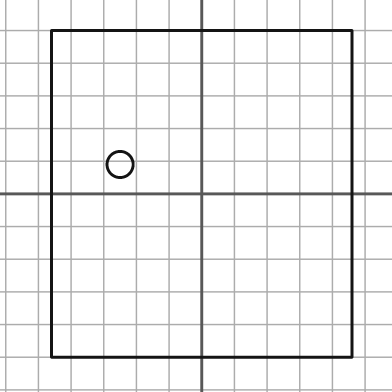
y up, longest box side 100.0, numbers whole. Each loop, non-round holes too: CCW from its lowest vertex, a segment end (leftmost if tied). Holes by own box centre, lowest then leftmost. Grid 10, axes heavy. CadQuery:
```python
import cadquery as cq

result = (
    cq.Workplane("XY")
    .moveTo(-46.0, -50.0)
    .lineTo(46.0, -50.0)
    .lineTo(46.0, 50.0)
    .lineTo(-46.0, 50.0)
    .close()
    .moveTo(-25.0, 9.0)
    .circle(4.0)
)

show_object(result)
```